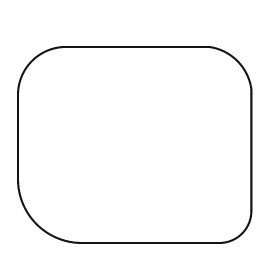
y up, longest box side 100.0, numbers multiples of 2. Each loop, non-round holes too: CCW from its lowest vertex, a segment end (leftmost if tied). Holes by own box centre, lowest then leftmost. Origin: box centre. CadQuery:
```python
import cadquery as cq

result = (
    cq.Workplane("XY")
    .moveTo(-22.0, -42.0)
    .lineTo(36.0, -42.0)
    .threePointArc((46.0, -38.0), (50.0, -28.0))
    .lineTo(50.0, 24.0)
    .threePointArc((44.0, 36.0), (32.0, 42.0))
    .lineTo(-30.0, 42.0)
    .threePointArc((-44.0, 36.0), (-50.0, 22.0))
    .lineTo(-50.0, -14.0)
    .threePointArc((-42.0, -34.0), (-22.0, -42.0))
    .close()
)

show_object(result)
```